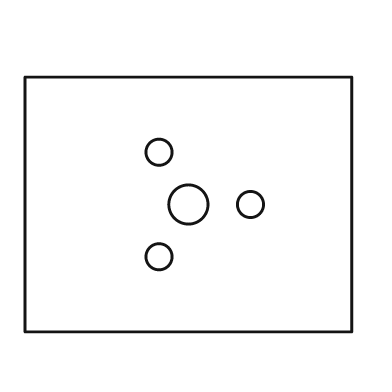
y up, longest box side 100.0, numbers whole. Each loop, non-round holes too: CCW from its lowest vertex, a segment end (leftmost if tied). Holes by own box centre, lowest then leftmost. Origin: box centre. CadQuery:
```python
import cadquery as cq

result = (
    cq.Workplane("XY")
    .moveTo(-50.0, -39.0)
    .lineTo(50.0, -39.0)
    .lineTo(50.0, 39.0)
    .lineTo(-50.0, 39.0)
    .close()
    .moveTo(-9.0, -16.0)
    .circle(4.0)
    .moveTo(0.0, 0.0)
    .circle(6.0)
    .moveTo(19.0, 0.0)
    .circle(4.0)
    .moveTo(-9.0, 16.0)
    .circle(4.0)
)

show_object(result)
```